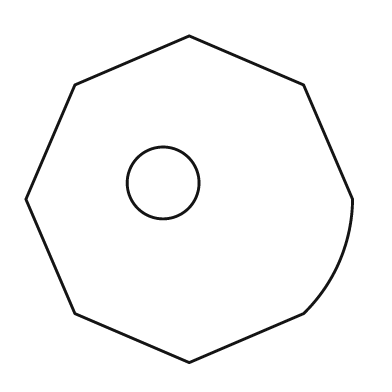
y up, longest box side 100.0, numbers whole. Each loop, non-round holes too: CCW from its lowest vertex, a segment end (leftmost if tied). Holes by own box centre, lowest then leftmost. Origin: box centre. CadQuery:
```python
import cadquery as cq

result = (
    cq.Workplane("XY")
    .moveTo(0.0, -50.0)
    .lineTo(35.0, -35.0)
    .threePointArc((46.0, -19.0), (50.0, 0.0))
    .lineTo(35.0, 35.0)
    .lineTo(0.0, 50.0)
    .lineTo(-35.0, 35.0)
    .lineTo(-50.0, 0.0)
    .lineTo(-35.0, -35.0)
    .close()
    .moveTo(-8.0, 5.0)
    .circle(11.0)
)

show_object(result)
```